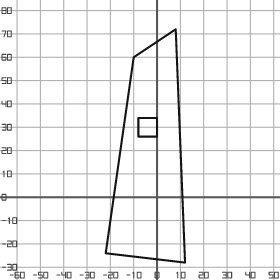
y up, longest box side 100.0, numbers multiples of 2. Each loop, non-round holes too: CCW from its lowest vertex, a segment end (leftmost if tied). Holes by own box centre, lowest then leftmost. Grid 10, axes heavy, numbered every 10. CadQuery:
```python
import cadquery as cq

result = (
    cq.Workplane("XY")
    .moveTo(12.0, -28.0)
    .lineTo(8.0, 72.0)
    .lineTo(-10.0, 60.0)
    .lineTo(-22.0, -24.0)
    .close()
    .moveTo(-8.0, 26.0)
    .lineTo(0.0, 26.0)
    .lineTo(0.0, 34.0)
    .lineTo(-8.0, 34.0)
    .close()
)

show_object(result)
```